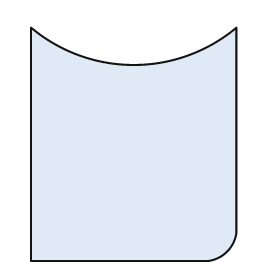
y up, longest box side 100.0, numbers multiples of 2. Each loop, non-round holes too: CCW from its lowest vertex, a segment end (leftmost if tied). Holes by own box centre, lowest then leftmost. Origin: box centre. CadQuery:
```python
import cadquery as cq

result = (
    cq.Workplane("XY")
    .moveTo(-44.0, -50.0)
    .lineTo(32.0, -50.0)
    .threePointArc((40.0, -46.0), (44.0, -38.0))
    .lineTo(44.0, 50.0)
    .threePointArc((0.0, 34.0), (-44.0, 50.0))
    .close()
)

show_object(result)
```